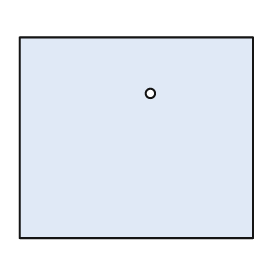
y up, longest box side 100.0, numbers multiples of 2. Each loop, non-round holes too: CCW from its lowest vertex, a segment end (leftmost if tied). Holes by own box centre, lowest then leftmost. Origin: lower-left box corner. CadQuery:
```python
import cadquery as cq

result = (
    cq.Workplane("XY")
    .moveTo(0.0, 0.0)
    .lineTo(100.0, 0.0)
    .lineTo(100.0, 86.0)
    .lineTo(0.0, 86.0)
    .close()
    .moveTo(56.0, 62.0)
    .circle(2.0)
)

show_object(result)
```